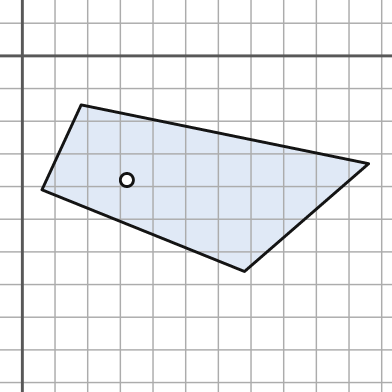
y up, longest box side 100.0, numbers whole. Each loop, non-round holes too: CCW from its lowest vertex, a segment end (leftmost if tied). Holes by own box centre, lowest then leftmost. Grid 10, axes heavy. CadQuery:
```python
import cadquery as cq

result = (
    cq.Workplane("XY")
    .moveTo(68.0, -66.0)
    .lineTo(106.0, -33.0)
    .lineTo(18.0, -15.0)
    .lineTo(6.0, -41.0)
    .close()
    .moveTo(32.0, -38.0)
    .circle(2.0)
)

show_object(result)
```